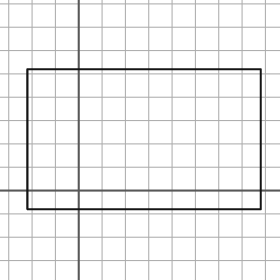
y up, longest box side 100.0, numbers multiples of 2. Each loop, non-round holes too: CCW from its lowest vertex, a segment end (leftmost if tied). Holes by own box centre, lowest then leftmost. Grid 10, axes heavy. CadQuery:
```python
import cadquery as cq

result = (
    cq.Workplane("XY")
    .moveTo(-22.0, -8.0)
    .lineTo(78.0, -8.0)
    .lineTo(78.0, 52.0)
    .lineTo(-22.0, 52.0)
    .close()
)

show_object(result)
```